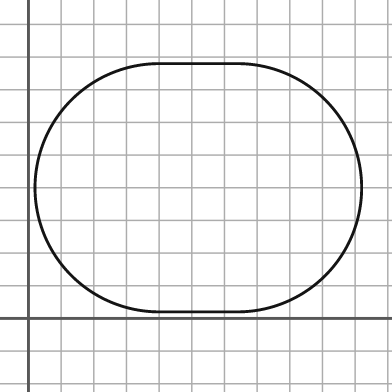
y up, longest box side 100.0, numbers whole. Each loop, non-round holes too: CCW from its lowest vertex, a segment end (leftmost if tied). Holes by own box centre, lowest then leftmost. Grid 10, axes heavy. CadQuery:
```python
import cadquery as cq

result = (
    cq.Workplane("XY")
    .moveTo(40.0, 2.0)
    .lineTo(64.0, 2.0)
    .threePointArc((102.0, 40.0), (64.0, 78.0))
    .lineTo(40.0, 78.0)
    .threePointArc((2.0, 40.0), (40.0, 2.0))
    .close()
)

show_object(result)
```